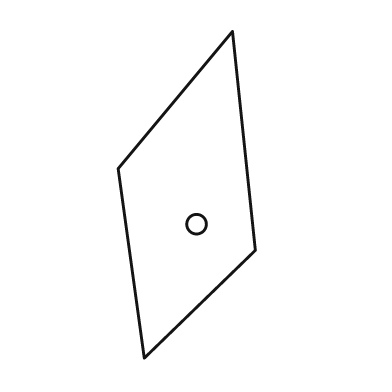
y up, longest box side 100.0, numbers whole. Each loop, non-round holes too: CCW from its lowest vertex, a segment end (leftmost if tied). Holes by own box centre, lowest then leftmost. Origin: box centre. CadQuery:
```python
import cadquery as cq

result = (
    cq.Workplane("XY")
    .moveTo(-13.0, -50.0)
    .lineTo(21.0, -17.0)
    .lineTo(14.0, 50.0)
    .lineTo(-21.0, 8.0)
    .close()
    .moveTo(3.0, -9.0)
    .circle(3.0)
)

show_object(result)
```